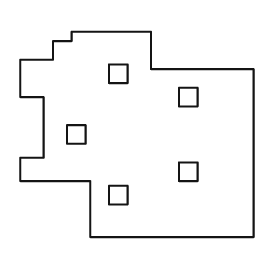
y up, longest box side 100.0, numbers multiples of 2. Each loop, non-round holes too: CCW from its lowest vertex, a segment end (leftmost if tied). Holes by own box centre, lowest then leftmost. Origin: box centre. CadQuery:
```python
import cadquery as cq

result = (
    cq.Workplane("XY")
    .moveTo(-20.0, -44.0)
    .lineTo(50.0, -44.0)
    .lineTo(50.0, 28.0)
    .lineTo(6.0, 28.0)
    .lineTo(6.0, 44.0)
    .lineTo(-28.0, 44.0)
    .lineTo(-28.0, 40.0)
    .lineTo(-36.0, 40.0)
    .lineTo(-36.0, 32.0)
    .lineTo(-50.0, 32.0)
    .lineTo(-50.0, 16.0)
    .lineTo(-40.0, 16.0)
    .lineTo(-40.0, -10.0)
    .lineTo(-50.0, -10.0)
    .lineTo(-50.0, -20.0)
    .lineTo(-20.0, -20.0)
    .close()
    .moveTo(-12.0, -30.0)
    .lineTo(-4.0, -30.0)
    .lineTo(-4.0, -22.0)
    .lineTo(-12.0, -22.0)
    .close()
    .moveTo(18.0, -20.0)
    .lineTo(26.0, -20.0)
    .lineTo(26.0, -12.0)
    .lineTo(18.0, -12.0)
    .close()
    .moveTo(-30.0, -4.0)
    .lineTo(-22.0, -4.0)
    .lineTo(-22.0, 4.0)
    .lineTo(-30.0, 4.0)
    .close()
    .moveTo(18.0, 12.0)
    .lineTo(26.0, 12.0)
    .lineTo(26.0, 20.0)
    .lineTo(18.0, 20.0)
    .close()
    .moveTo(-12.0, 22.0)
    .lineTo(-4.0, 22.0)
    .lineTo(-4.0, 30.0)
    .lineTo(-12.0, 30.0)
    .close()
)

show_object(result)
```